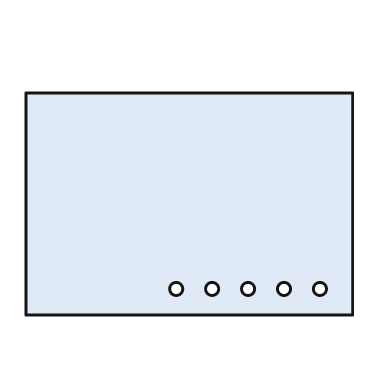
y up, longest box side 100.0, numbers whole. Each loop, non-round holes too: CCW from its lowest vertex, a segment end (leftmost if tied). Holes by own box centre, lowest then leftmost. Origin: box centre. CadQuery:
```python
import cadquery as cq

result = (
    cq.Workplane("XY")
    .moveTo(-50.0, -34.0)
    .lineTo(50.0, -34.0)
    .lineTo(50.0, 34.0)
    .lineTo(-50.0, 34.0)
    .close()
    .moveTo(-4.0, -26.0)
    .circle(2.0)
    .moveTo(7.0, -26.0)
    .circle(2.0)
    .moveTo(18.0, -26.0)
    .circle(2.0)
    .moveTo(29.0, -26.0)
    .circle(2.0)
    .moveTo(40.0, -26.0)
    .circle(2.0)
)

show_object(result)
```